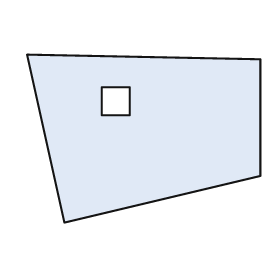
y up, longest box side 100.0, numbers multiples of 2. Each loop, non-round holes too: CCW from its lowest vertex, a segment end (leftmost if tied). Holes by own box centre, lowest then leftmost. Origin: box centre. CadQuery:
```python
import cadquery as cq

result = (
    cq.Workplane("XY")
    .moveTo(-34.0, -36.0)
    .lineTo(50.0, -16.0)
    .lineTo(50.0, 34.0)
    .lineTo(-50.0, 36.0)
    .close()
    .moveTo(-18.0, 10.0)
    .lineTo(-6.0, 10.0)
    .lineTo(-6.0, 22.0)
    .lineTo(-18.0, 22.0)
    .close()
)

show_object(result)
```